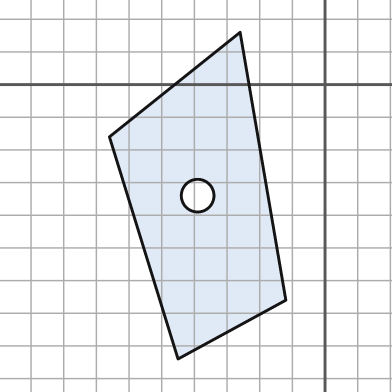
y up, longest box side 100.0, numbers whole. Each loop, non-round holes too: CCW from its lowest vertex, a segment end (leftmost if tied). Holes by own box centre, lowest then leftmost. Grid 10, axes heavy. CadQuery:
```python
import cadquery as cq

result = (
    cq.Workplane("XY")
    .moveTo(-45.0, -84.0)
    .lineTo(-12.0, -66.0)
    .lineTo(-26.0, 16.0)
    .lineTo(-66.0, -16.0)
    .close()
    .moveTo(-39.0, -34.0)
    .circle(5.0)
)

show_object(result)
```